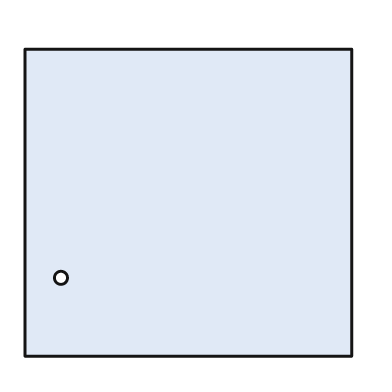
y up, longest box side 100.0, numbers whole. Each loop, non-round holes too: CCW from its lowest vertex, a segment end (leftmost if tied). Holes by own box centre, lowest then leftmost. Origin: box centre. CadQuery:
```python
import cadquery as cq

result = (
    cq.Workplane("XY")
    .moveTo(-50.0, -47.0)
    .lineTo(50.0, -47.0)
    .lineTo(50.0, 47.0)
    .lineTo(-50.0, 47.0)
    .close()
    .moveTo(-39.0, -23.0)
    .circle(2.0)
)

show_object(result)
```